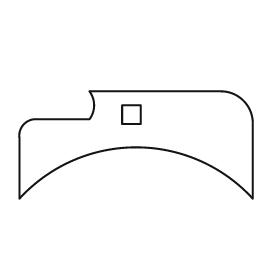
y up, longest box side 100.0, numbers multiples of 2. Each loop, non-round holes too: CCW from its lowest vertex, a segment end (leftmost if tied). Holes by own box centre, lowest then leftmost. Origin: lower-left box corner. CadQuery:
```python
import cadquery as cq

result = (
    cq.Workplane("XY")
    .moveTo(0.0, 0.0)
    .threePointArc((50.0, 22.0), (100.0, 0.0))
    .lineTo(100.0, 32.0)
    .threePointArc((96.0, 42.0), (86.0, 46.0))
    .lineTo(30.0, 46.0)
    .threePointArc((32.0, 40.0), (30.0, 34.0))
    .lineTo(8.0, 34.0)
    .threePointArc((2.0, 32.0), (0.0, 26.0))
    .close()
    .moveTo(44.0, 32.0)
    .lineTo(52.0, 32.0)
    .lineTo(52.0, 40.0)
    .lineTo(44.0, 40.0)
    .close()
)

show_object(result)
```